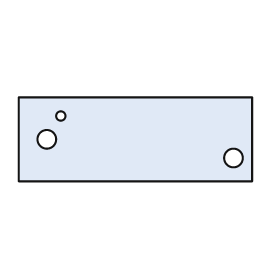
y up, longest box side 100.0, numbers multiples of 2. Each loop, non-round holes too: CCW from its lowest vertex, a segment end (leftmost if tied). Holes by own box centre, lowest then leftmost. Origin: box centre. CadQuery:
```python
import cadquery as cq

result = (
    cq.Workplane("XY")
    .moveTo(-50.0, -18.0)
    .lineTo(50.0, -18.0)
    .lineTo(50.0, 18.0)
    .lineTo(-50.0, 18.0)
    .close()
    .moveTo(42.0, -8.0)
    .circle(4.0)
    .moveTo(-38.0, 0.0)
    .circle(4.0)
    .moveTo(-32.0, 10.0)
    .circle(2.0)
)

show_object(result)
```